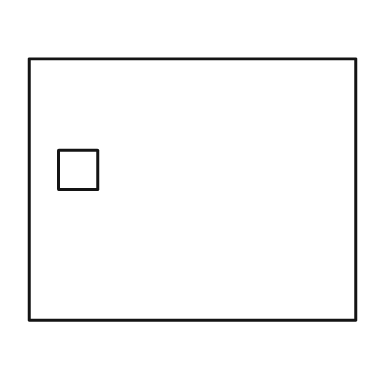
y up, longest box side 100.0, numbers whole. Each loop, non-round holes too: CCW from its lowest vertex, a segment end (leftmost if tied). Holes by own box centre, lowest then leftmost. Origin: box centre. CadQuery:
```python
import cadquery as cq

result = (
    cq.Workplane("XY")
    .moveTo(-50.0, -40.0)
    .lineTo(50.0, -40.0)
    .lineTo(50.0, 40.0)
    .lineTo(-50.0, 40.0)
    .close()
    .moveTo(-41.0, 0.0)
    .lineTo(-29.0, 0.0)
    .lineTo(-29.0, 12.0)
    .lineTo(-41.0, 12.0)
    .close()
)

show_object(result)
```